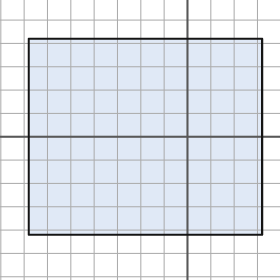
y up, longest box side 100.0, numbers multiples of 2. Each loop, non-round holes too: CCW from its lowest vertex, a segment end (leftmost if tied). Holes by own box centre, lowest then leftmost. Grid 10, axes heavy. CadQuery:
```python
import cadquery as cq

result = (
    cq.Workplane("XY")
    .moveTo(-68.0, -42.0)
    .lineTo(32.0, -42.0)
    .lineTo(32.0, 42.0)
    .lineTo(-68.0, 42.0)
    .close()
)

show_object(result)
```